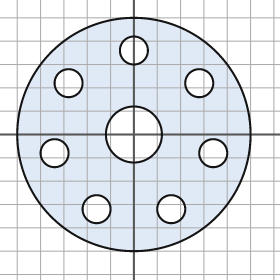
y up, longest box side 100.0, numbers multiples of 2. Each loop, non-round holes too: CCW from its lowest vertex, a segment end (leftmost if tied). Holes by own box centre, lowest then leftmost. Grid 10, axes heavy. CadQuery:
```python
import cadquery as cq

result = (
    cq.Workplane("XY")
    .moveTo(0.0, 0.0)
    .circle(50.0)
    .moveTo(-16.0, -32.0)
    .circle(6.0)
    .moveTo(16.0, -32.0)
    .circle(6.0)
    .moveTo(-34.0, -8.0)
    .circle(6.0)
    .moveTo(34.0, -8.0)
    .circle(6.0)
    .moveTo(0.0, 0.0)
    .circle(12.0)
    .moveTo(-28.0, 22.0)
    .circle(6.0)
    .moveTo(28.0, 22.0)
    .circle(6.0)
    .moveTo(0.0, 36.0)
    .circle(6.0)
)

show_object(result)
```